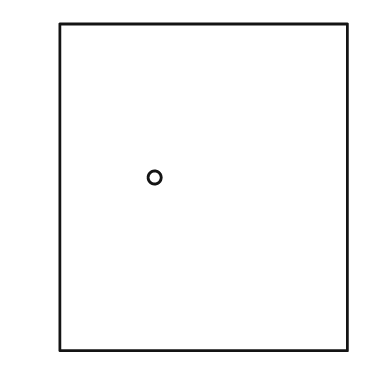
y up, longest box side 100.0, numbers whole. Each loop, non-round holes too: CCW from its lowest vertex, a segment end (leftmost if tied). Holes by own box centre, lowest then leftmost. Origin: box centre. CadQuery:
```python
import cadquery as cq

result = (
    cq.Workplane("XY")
    .moveTo(-44.0, -50.0)
    .lineTo(44.0, -50.0)
    .lineTo(44.0, 50.0)
    .lineTo(-44.0, 50.0)
    .close()
    .moveTo(-15.0, 3.0)
    .circle(2.0)
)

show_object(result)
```